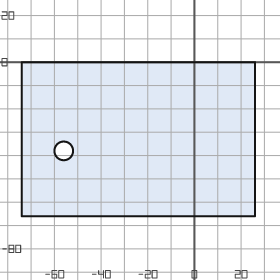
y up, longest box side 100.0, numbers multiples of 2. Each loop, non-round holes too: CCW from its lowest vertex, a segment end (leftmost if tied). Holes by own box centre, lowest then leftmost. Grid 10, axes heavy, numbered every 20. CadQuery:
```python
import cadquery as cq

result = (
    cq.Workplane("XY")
    .moveTo(-74.0, -66.0)
    .lineTo(26.0, -66.0)
    .lineTo(26.0, 0.0)
    .lineTo(-74.0, 0.0)
    .close()
    .moveTo(-56.0, -38.0)
    .circle(4.0)
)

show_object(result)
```